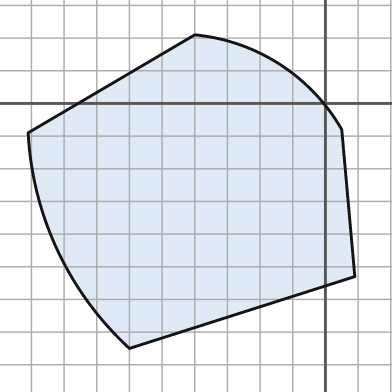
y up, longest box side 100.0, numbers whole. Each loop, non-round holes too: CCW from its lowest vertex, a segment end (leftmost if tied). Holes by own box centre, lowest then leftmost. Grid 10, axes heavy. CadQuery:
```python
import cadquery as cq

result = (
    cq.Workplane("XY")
    .moveTo(-60.0, -75.0)
    .lineTo(9.0, -53.0)
    .lineTo(5.0, -8.0)
    .threePointArc((-14.0, 12.0), (-40.0, 21.0))
    .lineTo(-91.0, -9.0)
    .threePointArc((-82.0, -45.0), (-60.0, -75.0))
    .close()
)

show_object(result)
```